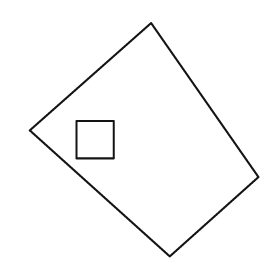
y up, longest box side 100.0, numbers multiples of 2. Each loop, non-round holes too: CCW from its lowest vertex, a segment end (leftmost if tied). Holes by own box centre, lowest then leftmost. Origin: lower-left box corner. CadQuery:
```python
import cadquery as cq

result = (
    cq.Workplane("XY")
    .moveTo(60.0, 0.0)
    .lineTo(98.0, 34.0)
    .lineTo(52.0, 100.0)
    .lineTo(0.0, 54.0)
    .close()
    .moveTo(20.0, 42.0)
    .lineTo(36.0, 42.0)
    .lineTo(36.0, 58.0)
    .lineTo(20.0, 58.0)
    .close()
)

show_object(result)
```